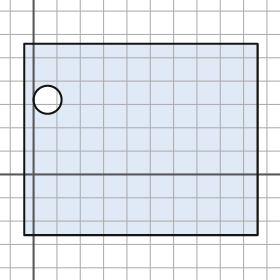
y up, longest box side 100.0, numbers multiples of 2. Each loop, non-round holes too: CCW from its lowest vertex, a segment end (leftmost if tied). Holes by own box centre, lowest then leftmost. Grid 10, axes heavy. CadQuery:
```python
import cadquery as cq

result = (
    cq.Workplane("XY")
    .moveTo(-4.0, -26.0)
    .lineTo(96.0, -26.0)
    .lineTo(96.0, 56.0)
    .lineTo(-4.0, 56.0)
    .close()
    .moveTo(6.0, 32.0)
    .circle(6.0)
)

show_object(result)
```